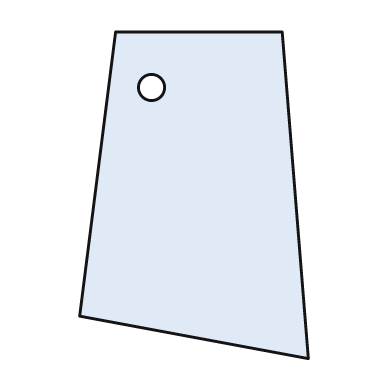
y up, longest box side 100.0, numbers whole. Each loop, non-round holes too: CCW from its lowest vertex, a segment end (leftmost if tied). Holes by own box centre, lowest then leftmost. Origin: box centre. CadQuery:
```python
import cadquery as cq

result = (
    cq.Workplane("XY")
    .moveTo(35.0, -50.0)
    .lineTo(27.0, 50.0)
    .lineTo(-24.0, 50.0)
    .lineTo(-35.0, -37.0)
    .close()
    .moveTo(-13.0, 33.0)
    .circle(4.0)
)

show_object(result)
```